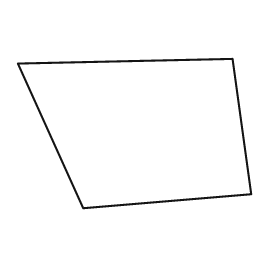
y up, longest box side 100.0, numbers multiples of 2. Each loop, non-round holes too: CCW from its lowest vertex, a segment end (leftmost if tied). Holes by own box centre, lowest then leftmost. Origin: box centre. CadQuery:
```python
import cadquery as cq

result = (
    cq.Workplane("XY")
    .moveTo(-22.0, -32.0)
    .lineTo(50.0, -26.0)
    .lineTo(42.0, 32.0)
    .lineTo(-50.0, 30.0)
    .close()
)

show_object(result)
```